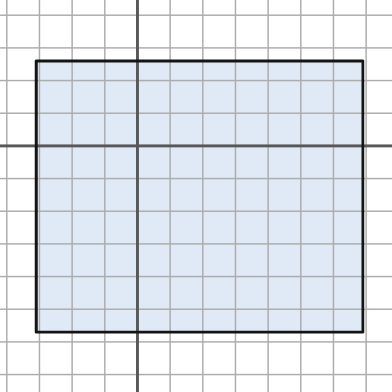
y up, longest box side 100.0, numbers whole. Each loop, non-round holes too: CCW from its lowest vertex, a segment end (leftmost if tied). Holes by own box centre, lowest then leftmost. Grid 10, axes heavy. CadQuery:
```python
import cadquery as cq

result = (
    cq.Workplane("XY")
    .moveTo(-31.0, -57.0)
    .lineTo(69.0, -57.0)
    .lineTo(69.0, 26.0)
    .lineTo(-31.0, 26.0)
    .close()
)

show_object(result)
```